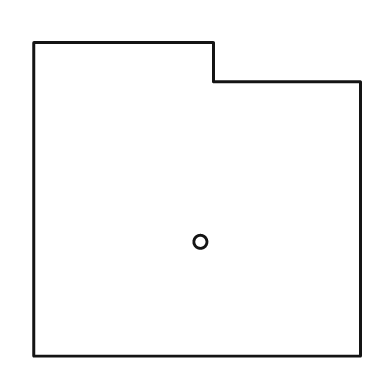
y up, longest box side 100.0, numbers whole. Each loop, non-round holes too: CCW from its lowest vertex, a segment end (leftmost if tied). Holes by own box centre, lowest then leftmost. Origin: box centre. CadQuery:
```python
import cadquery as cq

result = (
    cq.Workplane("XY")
    .moveTo(-50.0, -48.0)
    .lineTo(50.0, -48.0)
    .lineTo(50.0, 36.0)
    .lineTo(5.0, 36.0)
    .lineTo(5.0, 48.0)
    .lineTo(-50.0, 48.0)
    .close()
    .moveTo(1.0, -13.0)
    .circle(2.0)
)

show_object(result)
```